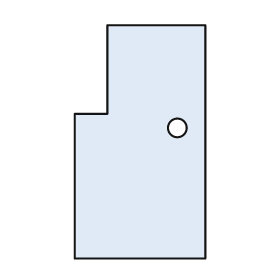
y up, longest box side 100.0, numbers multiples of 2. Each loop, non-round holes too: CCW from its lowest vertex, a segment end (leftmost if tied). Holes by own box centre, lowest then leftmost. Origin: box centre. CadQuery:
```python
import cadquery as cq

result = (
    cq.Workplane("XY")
    .moveTo(-28.0, -50.0)
    .lineTo(28.0, -50.0)
    .lineTo(28.0, 50.0)
    .lineTo(-14.0, 50.0)
    .lineTo(-14.0, 12.0)
    .lineTo(-28.0, 12.0)
    .close()
    .moveTo(16.0, 6.0)
    .circle(4.0)
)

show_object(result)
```